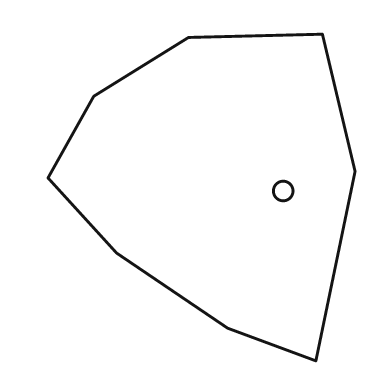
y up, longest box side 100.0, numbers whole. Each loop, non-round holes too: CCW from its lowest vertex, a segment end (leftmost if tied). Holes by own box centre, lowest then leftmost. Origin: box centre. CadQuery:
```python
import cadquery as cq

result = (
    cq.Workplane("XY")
    .moveTo(35.0, -50.0)
    .lineTo(47.0, 8.0)
    .lineTo(37.0, 50.0)
    .lineTo(-4.0, 49.0)
    .lineTo(-33.0, 31.0)
    .lineTo(-47.0, 6.0)
    .lineTo(-26.0, -17.0)
    .lineTo(8.0, -40.0)
    .close()
    .moveTo(25.0, 2.0)
    .circle(3.0)
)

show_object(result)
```